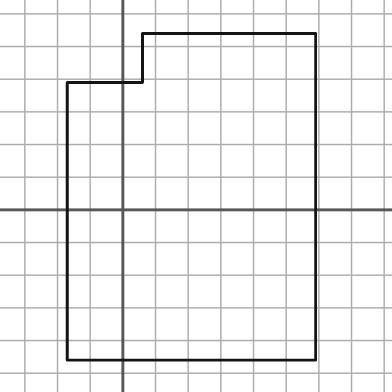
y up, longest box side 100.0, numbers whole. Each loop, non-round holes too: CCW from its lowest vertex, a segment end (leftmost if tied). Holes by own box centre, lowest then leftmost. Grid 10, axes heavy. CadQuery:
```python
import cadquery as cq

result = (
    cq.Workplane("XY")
    .moveTo(-17.0, -46.0)
    .lineTo(59.0, -46.0)
    .lineTo(59.0, 54.0)
    .lineTo(6.0, 54.0)
    .lineTo(6.0, 39.0)
    .lineTo(-17.0, 39.0)
    .close()
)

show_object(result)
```